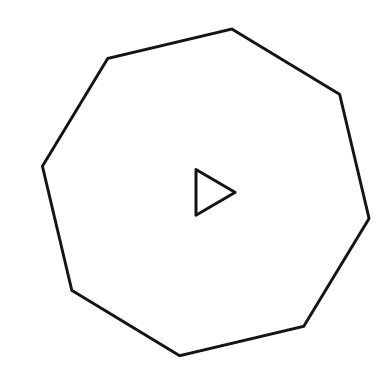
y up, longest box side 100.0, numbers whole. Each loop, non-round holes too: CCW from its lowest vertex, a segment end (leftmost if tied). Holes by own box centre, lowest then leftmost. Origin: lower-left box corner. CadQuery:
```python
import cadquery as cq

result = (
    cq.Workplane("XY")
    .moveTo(42.0, 0.0)
    .lineTo(80.0, 9.0)
    .lineTo(100.0, 42.0)
    .lineTo(91.0, 80.0)
    .lineTo(58.0, 100.0)
    .lineTo(20.0, 91.0)
    .lineTo(0.0, 58.0)
    .lineTo(9.0, 20.0)
    .close()
    .moveTo(47.0, 43.0)
    .lineTo(59.0, 50.0)
    .lineTo(47.0, 57.0)
    .close()
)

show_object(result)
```